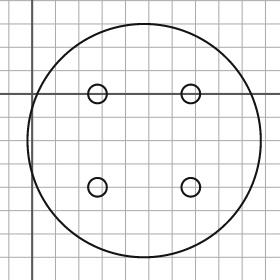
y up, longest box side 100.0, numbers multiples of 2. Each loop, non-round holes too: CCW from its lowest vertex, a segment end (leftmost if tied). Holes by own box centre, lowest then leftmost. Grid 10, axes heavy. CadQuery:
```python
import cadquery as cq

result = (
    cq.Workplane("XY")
    .moveTo(48.0, -20.0)
    .circle(50.0)
    .moveTo(28.0, -40.0)
    .circle(4.0)
    .moveTo(68.0, -40.0)
    .circle(4.0)
    .moveTo(28.0, 0.0)
    .circle(4.0)
    .moveTo(68.0, 0.0)
    .circle(4.0)
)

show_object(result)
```